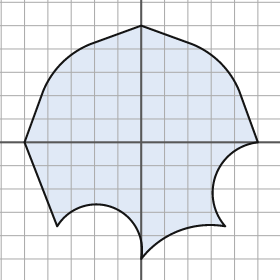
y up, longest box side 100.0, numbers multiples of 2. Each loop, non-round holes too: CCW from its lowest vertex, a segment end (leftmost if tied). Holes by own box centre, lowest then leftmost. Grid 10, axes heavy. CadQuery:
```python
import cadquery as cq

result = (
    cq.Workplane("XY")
    .moveTo(0.0, -50.0)
    .threePointArc((16.0, -38.0), (36.0, -36.0))
    .threePointArc((32.0, -14.0), (50.0, 0.0))
    .lineTo(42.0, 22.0)
    .threePointArc((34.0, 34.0), (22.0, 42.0))
    .lineTo(0.0, 50.0)
    .lineTo(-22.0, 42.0)
    .threePointArc((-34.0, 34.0), (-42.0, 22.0))
    .lineTo(-50.0, 0.0)
    .lineTo(-36.0, -36.0)
    .threePointArc((-12.0, -28.0), (0.0, -50.0))
    .close()
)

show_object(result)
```